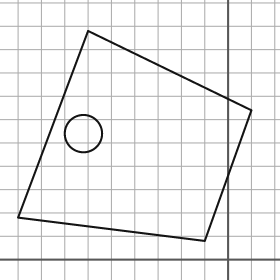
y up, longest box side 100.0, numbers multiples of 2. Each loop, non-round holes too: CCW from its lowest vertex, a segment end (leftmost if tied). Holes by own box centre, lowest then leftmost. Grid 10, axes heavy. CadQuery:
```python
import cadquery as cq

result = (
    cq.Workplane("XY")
    .moveTo(-10.0, 8.0)
    .lineTo(10.0, 64.0)
    .lineTo(-60.0, 98.0)
    .lineTo(-90.0, 18.0)
    .close()
    .moveTo(-62.0, 54.0)
    .circle(8.0)
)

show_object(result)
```